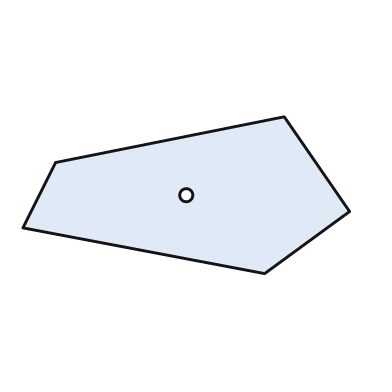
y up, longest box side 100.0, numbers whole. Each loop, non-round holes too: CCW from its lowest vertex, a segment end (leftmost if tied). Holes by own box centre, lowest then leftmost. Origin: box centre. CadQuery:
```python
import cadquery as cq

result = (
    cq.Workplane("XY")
    .moveTo(24.0, -24.0)
    .lineTo(50.0, -5.0)
    .lineTo(30.0, 24.0)
    .lineTo(-40.0, 10.0)
    .lineTo(-50.0, -10.0)
    .close()
    .moveTo(0.0, 0.0)
    .circle(2.0)
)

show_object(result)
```